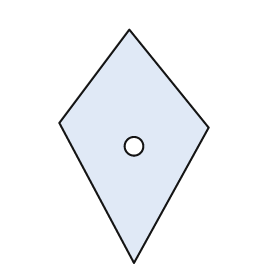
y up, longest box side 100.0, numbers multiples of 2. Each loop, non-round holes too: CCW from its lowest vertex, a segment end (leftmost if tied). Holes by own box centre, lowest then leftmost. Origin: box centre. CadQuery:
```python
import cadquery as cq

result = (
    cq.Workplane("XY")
    .moveTo(0.0, -50.0)
    .lineTo(32.0, 8.0)
    .lineTo(-2.0, 50.0)
    .lineTo(-32.0, 10.0)
    .close()
    .moveTo(0.0, 0.0)
    .circle(4.0)
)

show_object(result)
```